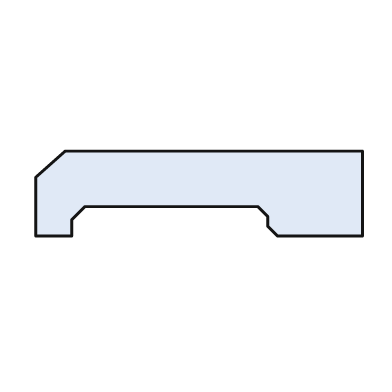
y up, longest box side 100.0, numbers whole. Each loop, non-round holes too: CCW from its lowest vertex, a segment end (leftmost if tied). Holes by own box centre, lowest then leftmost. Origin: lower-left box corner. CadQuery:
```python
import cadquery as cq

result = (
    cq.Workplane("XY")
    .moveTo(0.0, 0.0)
    .lineTo(11.0, 0.0)
    .lineTo(11.0, 5.0)
    .lineTo(15.0, 9.0)
    .lineTo(68.0, 9.0)
    .lineTo(71.0, 6.0)
    .lineTo(71.0, 3.0)
    .lineTo(74.0, 0.0)
    .lineTo(100.0, 0.0)
    .lineTo(100.0, 26.0)
    .lineTo(9.0, 26.0)
    .lineTo(0.0, 18.0)
    .close()
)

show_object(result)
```